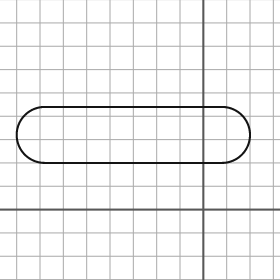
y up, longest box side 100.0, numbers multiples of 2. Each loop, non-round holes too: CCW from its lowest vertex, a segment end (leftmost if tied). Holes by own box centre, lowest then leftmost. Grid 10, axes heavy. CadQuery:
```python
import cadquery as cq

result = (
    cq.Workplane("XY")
    .moveTo(-68.0, 20.0)
    .lineTo(8.0, 20.0)
    .threePointArc((20.0, 32.0), (8.0, 44.0))
    .lineTo(-68.0, 44.0)
    .threePointArc((-80.0, 32.0), (-68.0, 20.0))
    .close()
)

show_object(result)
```